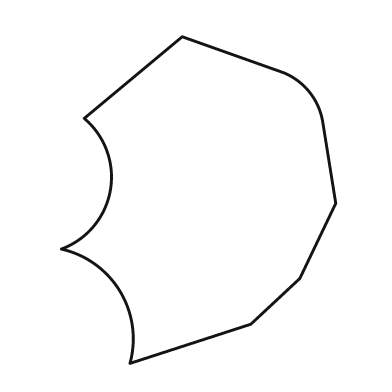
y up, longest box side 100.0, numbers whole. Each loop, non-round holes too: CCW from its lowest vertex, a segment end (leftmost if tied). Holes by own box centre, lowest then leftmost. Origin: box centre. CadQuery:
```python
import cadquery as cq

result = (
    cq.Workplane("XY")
    .moveTo(-21.0, -50.0)
    .lineTo(16.0, -38.0)
    .lineTo(31.0, -24.0)
    .lineTo(42.0, -1.0)
    .lineTo(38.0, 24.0)
    .threePointArc((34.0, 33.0), (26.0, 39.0))
    .lineTo(-5.0, 50.0)
    .lineTo(-35.0, 25.0)
    .threePointArc((-27.0, 3.0), (-42.0, -15.0))
    .threePointArc((-24.0, -28.0), (-21.0, -50.0))
    .close()
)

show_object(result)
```